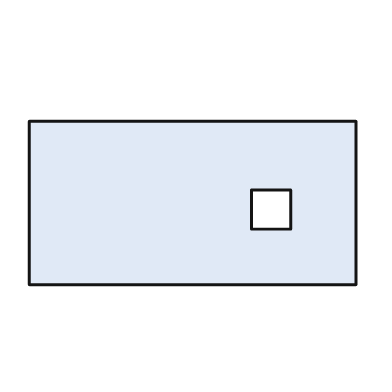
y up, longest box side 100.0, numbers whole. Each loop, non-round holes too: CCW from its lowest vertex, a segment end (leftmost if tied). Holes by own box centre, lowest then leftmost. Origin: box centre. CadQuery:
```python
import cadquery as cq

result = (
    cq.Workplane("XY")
    .moveTo(-50.0, -25.0)
    .lineTo(50.0, -25.0)
    .lineTo(50.0, 25.0)
    .lineTo(-50.0, 25.0)
    .close()
    .moveTo(18.0, -8.0)
    .lineTo(30.0, -8.0)
    .lineTo(30.0, 4.0)
    .lineTo(18.0, 4.0)
    .close()
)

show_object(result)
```